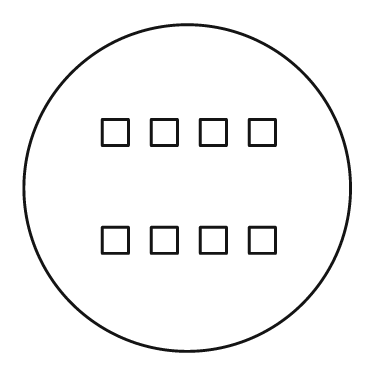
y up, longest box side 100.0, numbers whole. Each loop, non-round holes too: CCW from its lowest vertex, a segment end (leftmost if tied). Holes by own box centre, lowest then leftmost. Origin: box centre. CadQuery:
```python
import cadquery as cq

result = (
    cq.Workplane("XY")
    .moveTo(0.0, 0.0)
    .circle(50.0)
    .moveTo(-26.0, -20.0)
    .lineTo(-18.0, -20.0)
    .lineTo(-18.0, -12.0)
    .lineTo(-26.0, -12.0)
    .close()
    .moveTo(-11.0, -20.0)
    .lineTo(-3.0, -20.0)
    .lineTo(-3.0, -12.0)
    .lineTo(-11.0, -12.0)
    .close()
    .moveTo(4.0, -20.0)
    .lineTo(12.0, -20.0)
    .lineTo(12.0, -12.0)
    .lineTo(4.0, -12.0)
    .close()
    .moveTo(19.0, -20.0)
    .lineTo(27.0, -20.0)
    .lineTo(27.0, -12.0)
    .lineTo(19.0, -12.0)
    .close()
    .moveTo(-26.0, 13.0)
    .lineTo(-18.0, 13.0)
    .lineTo(-18.0, 21.0)
    .lineTo(-26.0, 21.0)
    .close()
    .moveTo(-11.0, 13.0)
    .lineTo(-3.0, 13.0)
    .lineTo(-3.0, 21.0)
    .lineTo(-11.0, 21.0)
    .close()
    .moveTo(4.0, 13.0)
    .lineTo(12.0, 13.0)
    .lineTo(12.0, 21.0)
    .lineTo(4.0, 21.0)
    .close()
    .moveTo(19.0, 13.0)
    .lineTo(27.0, 13.0)
    .lineTo(27.0, 21.0)
    .lineTo(19.0, 21.0)
    .close()
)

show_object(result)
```